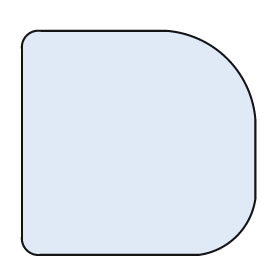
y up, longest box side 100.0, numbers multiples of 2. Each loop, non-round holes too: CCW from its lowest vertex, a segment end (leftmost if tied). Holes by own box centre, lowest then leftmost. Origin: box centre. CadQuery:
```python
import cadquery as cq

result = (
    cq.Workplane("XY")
    .moveTo(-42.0, -48.0)
    .lineTo(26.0, -48.0)
    .threePointArc((42.0, -40.0), (50.0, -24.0))
    .lineTo(50.0, 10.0)
    .threePointArc((38.0, 36.0), (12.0, 48.0))
    .lineTo(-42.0, 48.0)
    .threePointArc((-48.0, 46.0), (-50.0, 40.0))
    .lineTo(-50.0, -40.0)
    .threePointArc((-48.0, -46.0), (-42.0, -48.0))
    .close()
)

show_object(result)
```